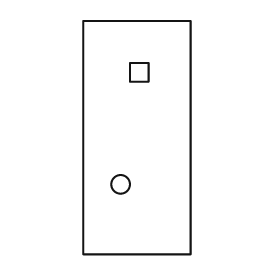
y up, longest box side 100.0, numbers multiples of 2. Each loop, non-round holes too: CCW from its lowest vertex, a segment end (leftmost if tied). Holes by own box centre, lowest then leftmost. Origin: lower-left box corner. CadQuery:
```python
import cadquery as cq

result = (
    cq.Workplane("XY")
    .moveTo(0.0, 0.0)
    .lineTo(46.0, 0.0)
    .lineTo(46.0, 100.0)
    .lineTo(0.0, 100.0)
    .close()
    .moveTo(16.0, 30.0)
    .circle(4.0)
    .moveTo(20.0, 74.0)
    .lineTo(28.0, 74.0)
    .lineTo(28.0, 82.0)
    .lineTo(20.0, 82.0)
    .close()
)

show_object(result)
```